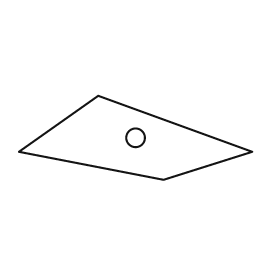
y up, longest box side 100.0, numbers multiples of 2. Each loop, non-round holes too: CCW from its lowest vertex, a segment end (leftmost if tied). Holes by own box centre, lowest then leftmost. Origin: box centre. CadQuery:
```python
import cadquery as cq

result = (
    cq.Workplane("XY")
    .moveTo(12.0, -18.0)
    .lineTo(50.0, -6.0)
    .lineTo(-16.0, 18.0)
    .lineTo(-50.0, -6.0)
    .close()
    .moveTo(0.0, 0.0)
    .circle(4.0)
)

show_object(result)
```